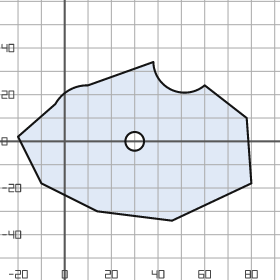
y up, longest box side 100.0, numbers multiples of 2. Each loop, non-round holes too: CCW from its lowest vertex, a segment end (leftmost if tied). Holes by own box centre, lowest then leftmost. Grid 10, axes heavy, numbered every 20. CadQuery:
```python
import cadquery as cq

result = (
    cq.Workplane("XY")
    .moveTo(46.0, -34.0)
    .lineTo(80.0, -18.0)
    .lineTo(78.0, 10.0)
    .lineTo(60.0, 24.0)
    .threePointArc((46.0, 22.0), (38.0, 34.0))
    .lineTo(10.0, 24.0)
    .threePointArc((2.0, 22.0), (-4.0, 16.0))
    .lineTo(-20.0, 2.0)
    .lineTo(-10.0, -18.0)
    .lineTo(14.0, -30.0)
    .close()
    .moveTo(30.0, 0.0)
    .circle(4.0)
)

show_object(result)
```